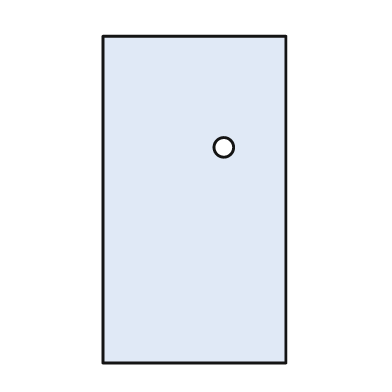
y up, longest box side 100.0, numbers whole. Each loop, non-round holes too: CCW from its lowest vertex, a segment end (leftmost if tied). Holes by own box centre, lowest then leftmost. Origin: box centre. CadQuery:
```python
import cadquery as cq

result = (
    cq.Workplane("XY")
    .moveTo(-28.0, -50.0)
    .lineTo(28.0, -50.0)
    .lineTo(28.0, 50.0)
    .lineTo(-28.0, 50.0)
    .close()
    .moveTo(9.0, 16.0)
    .circle(3.0)
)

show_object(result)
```